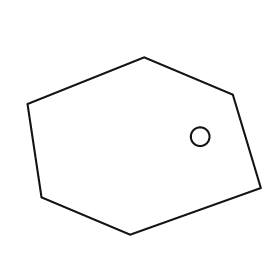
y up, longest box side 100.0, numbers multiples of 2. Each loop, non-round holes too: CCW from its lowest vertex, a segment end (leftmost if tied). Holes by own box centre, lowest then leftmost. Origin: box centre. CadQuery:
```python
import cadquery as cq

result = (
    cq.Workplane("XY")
    .moveTo(-6.0, -38.0)
    .lineTo(50.0, -18.0)
    .lineTo(38.0, 22.0)
    .lineTo(0.0, 38.0)
    .lineTo(-50.0, 18.0)
    .lineTo(-44.0, -22.0)
    .close()
    .moveTo(24.0, 4.0)
    .circle(4.0)
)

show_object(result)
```